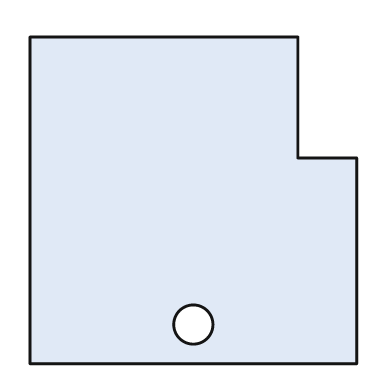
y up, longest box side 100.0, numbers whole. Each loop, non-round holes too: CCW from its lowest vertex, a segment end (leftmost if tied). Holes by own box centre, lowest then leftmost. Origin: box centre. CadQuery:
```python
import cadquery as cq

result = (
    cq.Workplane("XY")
    .moveTo(-50.0, -50.0)
    .lineTo(50.0, -50.0)
    .lineTo(50.0, 13.0)
    .lineTo(32.0, 13.0)
    .lineTo(32.0, 50.0)
    .lineTo(-50.0, 50.0)
    .close()
    .moveTo(0.0, -38.0)
    .circle(6.0)
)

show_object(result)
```